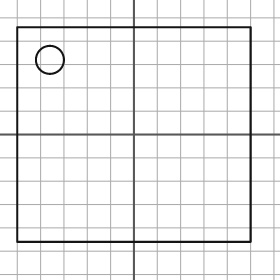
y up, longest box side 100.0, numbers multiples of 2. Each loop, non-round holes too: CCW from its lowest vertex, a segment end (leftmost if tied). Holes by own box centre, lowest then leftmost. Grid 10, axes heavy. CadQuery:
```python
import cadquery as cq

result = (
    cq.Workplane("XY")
    .moveTo(-50.0, -46.0)
    .lineTo(50.0, -46.0)
    .lineTo(50.0, 46.0)
    .lineTo(-50.0, 46.0)
    .close()
    .moveTo(-36.0, 32.0)
    .circle(6.0)
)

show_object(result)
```